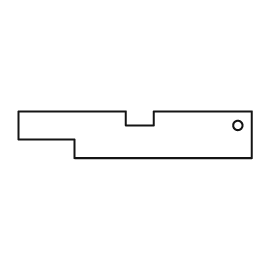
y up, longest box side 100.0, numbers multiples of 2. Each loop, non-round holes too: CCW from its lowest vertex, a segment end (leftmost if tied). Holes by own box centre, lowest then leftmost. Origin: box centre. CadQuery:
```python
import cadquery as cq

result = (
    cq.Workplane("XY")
    .moveTo(-26.0, -10.0)
    .lineTo(50.0, -10.0)
    .lineTo(50.0, 10.0)
    .lineTo(8.0, 10.0)
    .lineTo(8.0, 4.0)
    .lineTo(-4.0, 4.0)
    .lineTo(-4.0, 10.0)
    .lineTo(-50.0, 10.0)
    .lineTo(-50.0, -2.0)
    .lineTo(-26.0, -2.0)
    .close()
    .moveTo(44.0, 4.0)
    .circle(2.0)
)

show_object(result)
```